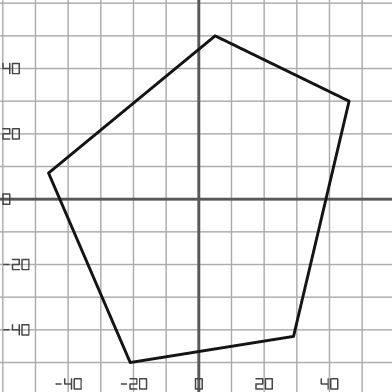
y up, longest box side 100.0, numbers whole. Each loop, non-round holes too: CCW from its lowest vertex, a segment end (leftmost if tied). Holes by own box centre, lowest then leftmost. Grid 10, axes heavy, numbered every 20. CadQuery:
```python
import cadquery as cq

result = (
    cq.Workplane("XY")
    .moveTo(-21.0, -50.0)
    .lineTo(29.0, -42.0)
    .lineTo(46.0, 30.0)
    .lineTo(5.0, 50.0)
    .lineTo(-46.0, 8.0)
    .close()
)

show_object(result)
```